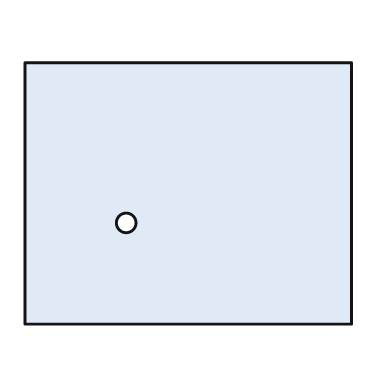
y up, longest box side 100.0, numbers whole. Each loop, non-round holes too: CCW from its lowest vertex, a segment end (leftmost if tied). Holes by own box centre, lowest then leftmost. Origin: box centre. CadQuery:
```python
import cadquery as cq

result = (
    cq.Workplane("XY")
    .moveTo(-50.0, -40.0)
    .lineTo(50.0, -40.0)
    .lineTo(50.0, 40.0)
    .lineTo(-50.0, 40.0)
    .close()
    .moveTo(-19.0, -9.0)
    .circle(3.0)
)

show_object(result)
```